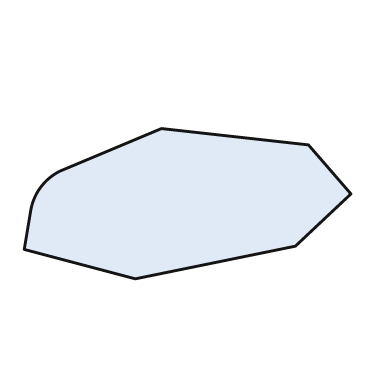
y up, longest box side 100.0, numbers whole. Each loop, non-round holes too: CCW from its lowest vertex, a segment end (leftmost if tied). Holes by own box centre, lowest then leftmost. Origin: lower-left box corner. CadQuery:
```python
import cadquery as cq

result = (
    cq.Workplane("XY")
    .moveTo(34.0, 0.0)
    .lineTo(83.0, 10.0)
    .lineTo(100.0, 26.0)
    .lineTo(87.0, 41.0)
    .lineTo(42.0, 46.0)
    .lineTo(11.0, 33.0)
    .threePointArc((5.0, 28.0), (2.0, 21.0))
    .lineTo(0.0, 9.0)
    .close()
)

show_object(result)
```